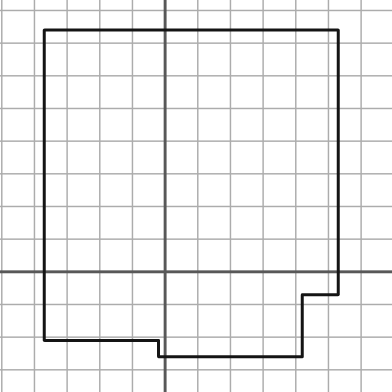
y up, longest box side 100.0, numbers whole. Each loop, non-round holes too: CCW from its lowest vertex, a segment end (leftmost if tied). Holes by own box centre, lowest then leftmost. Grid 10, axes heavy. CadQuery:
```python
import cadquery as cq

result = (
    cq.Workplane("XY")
    .moveTo(-2.0, -26.0)
    .lineTo(42.0, -26.0)
    .lineTo(42.0, -7.0)
    .lineTo(53.0, -7.0)
    .lineTo(53.0, 74.0)
    .lineTo(-37.0, 74.0)
    .lineTo(-37.0, -21.0)
    .lineTo(-2.0, -21.0)
    .close()
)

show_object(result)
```